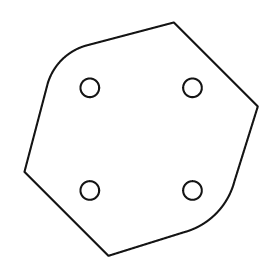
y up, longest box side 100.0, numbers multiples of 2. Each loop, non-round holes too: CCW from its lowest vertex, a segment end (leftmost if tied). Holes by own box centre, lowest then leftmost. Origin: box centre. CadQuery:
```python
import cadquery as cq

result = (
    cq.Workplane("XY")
    .moveTo(-14.0, -50.0)
    .lineTo(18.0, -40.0)
    .threePointArc((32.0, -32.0), (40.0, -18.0))
    .lineTo(50.0, 14.0)
    .lineTo(14.0, 50.0)
    .lineTo(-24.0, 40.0)
    .threePointArc((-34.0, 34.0), (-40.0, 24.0))
    .lineTo(-50.0, -14.0)
    .close()
    .moveTo(-22.0, -22.0)
    .circle(4.0)
    .moveTo(22.0, -22.0)
    .circle(4.0)
    .moveTo(-22.0, 22.0)
    .circle(4.0)
    .moveTo(22.0, 22.0)
    .circle(4.0)
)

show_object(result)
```